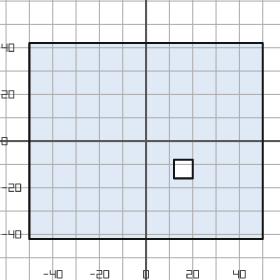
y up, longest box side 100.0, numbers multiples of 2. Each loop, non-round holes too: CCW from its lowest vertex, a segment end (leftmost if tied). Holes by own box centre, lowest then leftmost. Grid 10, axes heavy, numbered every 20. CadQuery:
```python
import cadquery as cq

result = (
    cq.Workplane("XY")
    .moveTo(-50.0, -42.0)
    .lineTo(50.0, -42.0)
    .lineTo(50.0, 42.0)
    .lineTo(-50.0, 42.0)
    .close()
    .moveTo(12.0, -16.0)
    .lineTo(20.0, -16.0)
    .lineTo(20.0, -8.0)
    .lineTo(12.0, -8.0)
    .close()
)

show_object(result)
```